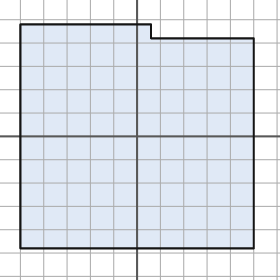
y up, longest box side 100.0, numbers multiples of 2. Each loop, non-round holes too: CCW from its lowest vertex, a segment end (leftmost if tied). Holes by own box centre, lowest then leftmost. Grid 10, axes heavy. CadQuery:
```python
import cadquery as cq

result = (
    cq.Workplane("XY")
    .moveTo(-50.0, -48.0)
    .lineTo(50.0, -48.0)
    .lineTo(50.0, 42.0)
    .lineTo(6.0, 42.0)
    .lineTo(6.0, 48.0)
    .lineTo(-50.0, 48.0)
    .close()
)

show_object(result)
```